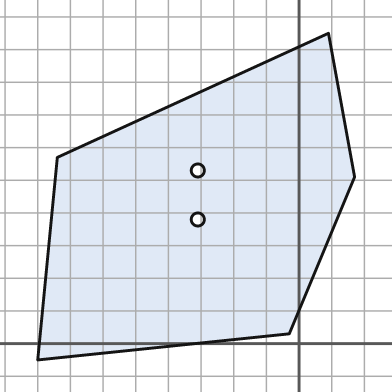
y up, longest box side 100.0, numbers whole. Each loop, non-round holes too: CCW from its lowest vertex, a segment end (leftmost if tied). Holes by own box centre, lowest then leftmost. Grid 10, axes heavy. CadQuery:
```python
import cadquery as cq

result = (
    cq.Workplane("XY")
    .moveTo(-80.0, -5.0)
    .lineTo(-3.0, 3.0)
    .lineTo(17.0, 51.0)
    .lineTo(9.0, 95.0)
    .lineTo(-74.0, 57.0)
    .close()
    .moveTo(-31.0, 38.0)
    .circle(2.0)
    .moveTo(-31.0, 53.0)
    .circle(2.0)
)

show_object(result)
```